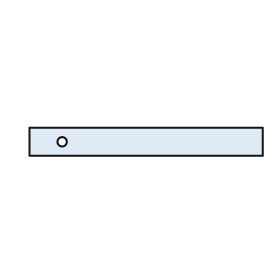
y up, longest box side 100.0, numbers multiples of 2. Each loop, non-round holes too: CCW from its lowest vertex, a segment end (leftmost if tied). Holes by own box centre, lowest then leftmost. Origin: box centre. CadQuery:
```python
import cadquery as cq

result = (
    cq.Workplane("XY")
    .moveTo(-50.0, -6.0)
    .lineTo(50.0, -6.0)
    .lineTo(50.0, 6.0)
    .lineTo(-50.0, 6.0)
    .close()
    .moveTo(-36.0, 0.0)
    .circle(2.0)
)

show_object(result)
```